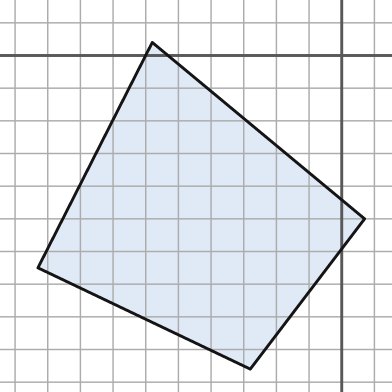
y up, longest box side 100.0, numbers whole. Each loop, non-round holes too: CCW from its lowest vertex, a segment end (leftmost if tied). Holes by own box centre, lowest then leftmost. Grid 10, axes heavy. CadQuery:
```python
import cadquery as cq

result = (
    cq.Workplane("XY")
    .moveTo(-28.0, -96.0)
    .lineTo(7.0, -50.0)
    .lineTo(-58.0, 4.0)
    .lineTo(-93.0, -65.0)
    .close()
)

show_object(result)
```